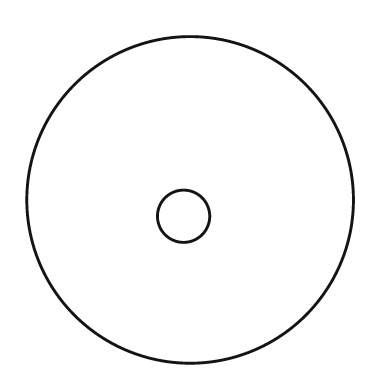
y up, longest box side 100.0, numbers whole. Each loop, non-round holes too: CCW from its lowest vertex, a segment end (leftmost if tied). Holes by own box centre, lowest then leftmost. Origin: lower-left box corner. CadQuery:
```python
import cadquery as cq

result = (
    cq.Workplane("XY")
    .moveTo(50.0, 50.0)
    .circle(50.0)
    .moveTo(48.0, 45.0)
    .circle(8.0)
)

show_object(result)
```